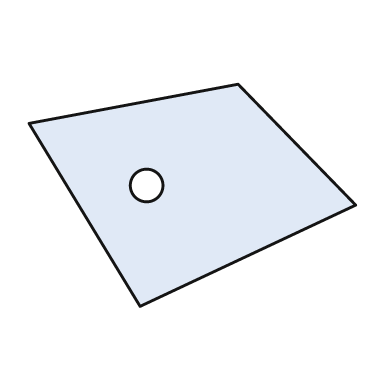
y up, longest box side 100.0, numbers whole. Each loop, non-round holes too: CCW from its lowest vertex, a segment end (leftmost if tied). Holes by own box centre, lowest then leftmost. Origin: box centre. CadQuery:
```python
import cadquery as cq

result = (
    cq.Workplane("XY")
    .moveTo(-16.0, -34.0)
    .lineTo(50.0, -3.0)
    .lineTo(14.0, 34.0)
    .lineTo(-50.0, 22.0)
    .close()
    .moveTo(-14.0, 3.0)
    .circle(5.0)
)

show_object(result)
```